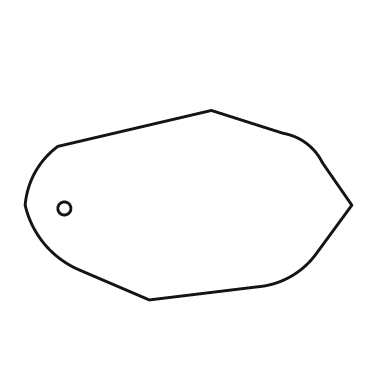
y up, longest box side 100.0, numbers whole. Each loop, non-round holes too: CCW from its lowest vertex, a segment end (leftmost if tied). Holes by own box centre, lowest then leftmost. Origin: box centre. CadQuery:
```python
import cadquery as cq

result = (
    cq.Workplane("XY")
    .moveTo(-12.0, -29.0)
    .lineTo(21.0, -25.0)
    .threePointArc((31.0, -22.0), (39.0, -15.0))
    .lineTo(50.0, 0.0)
    .lineTo(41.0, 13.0)
    .threePointArc((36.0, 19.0), (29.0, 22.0))
    .lineTo(7.0, 29.0)
    .lineTo(-40.0, 18.0)
    .threePointArc((-47.0, 10.0), (-50.0, 0.0))
    .threePointArc((-44.0, -12.0), (-33.0, -20.0))
    .close()
    .moveTo(-38.0, -1.0)
    .circle(2.0)
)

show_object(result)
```